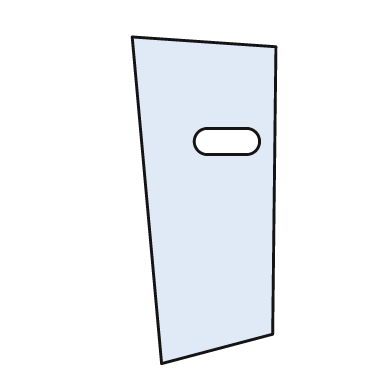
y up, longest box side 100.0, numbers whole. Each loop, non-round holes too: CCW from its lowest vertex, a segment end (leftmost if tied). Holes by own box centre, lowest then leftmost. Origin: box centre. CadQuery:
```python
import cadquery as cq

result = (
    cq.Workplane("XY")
    .moveTo(-13.0, -50.0)
    .lineTo(21.0, -41.0)
    .lineTo(22.0, 47.0)
    .lineTo(-22.0, 50.0)
    .close()
    .moveTo(1.0, 14.0)
    .lineTo(13.0, 14.0)
    .threePointArc((17.0, 18.0), (13.0, 22.0))
    .lineTo(1.0, 22.0)
    .threePointArc((-3.0, 18.0), (1.0, 14.0))
    .close()
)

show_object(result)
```